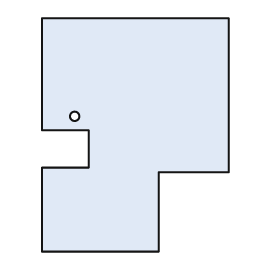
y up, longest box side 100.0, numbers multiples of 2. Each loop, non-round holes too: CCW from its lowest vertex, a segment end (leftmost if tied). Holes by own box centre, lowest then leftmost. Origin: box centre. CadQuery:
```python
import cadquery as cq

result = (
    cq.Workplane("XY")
    .moveTo(-40.0, -50.0)
    .lineTo(10.0, -50.0)
    .lineTo(10.0, -16.0)
    .lineTo(40.0, -16.0)
    .lineTo(40.0, 50.0)
    .lineTo(-40.0, 50.0)
    .lineTo(-40.0, 2.0)
    .lineTo(-20.0, 2.0)
    .lineTo(-20.0, -14.0)
    .lineTo(-40.0, -14.0)
    .close()
    .moveTo(-26.0, 8.0)
    .circle(2.0)
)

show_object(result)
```